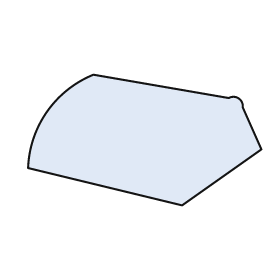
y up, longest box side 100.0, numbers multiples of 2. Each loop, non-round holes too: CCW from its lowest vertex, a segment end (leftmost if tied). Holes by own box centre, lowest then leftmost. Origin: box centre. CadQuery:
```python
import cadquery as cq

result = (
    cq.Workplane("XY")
    .moveTo(16.0, -28.0)
    .lineTo(50.0, -4.0)
    .lineTo(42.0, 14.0)
    .threePointArc((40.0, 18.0), (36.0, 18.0))
    .lineTo(-22.0, 28.0)
    .threePointArc((-42.0, 12.0), (-50.0, -12.0))
    .close()
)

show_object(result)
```